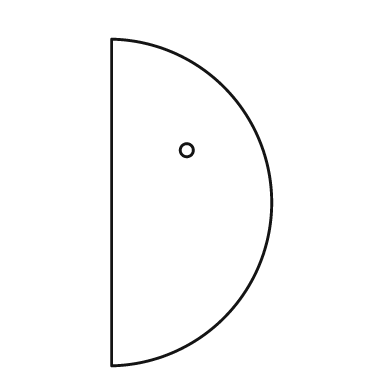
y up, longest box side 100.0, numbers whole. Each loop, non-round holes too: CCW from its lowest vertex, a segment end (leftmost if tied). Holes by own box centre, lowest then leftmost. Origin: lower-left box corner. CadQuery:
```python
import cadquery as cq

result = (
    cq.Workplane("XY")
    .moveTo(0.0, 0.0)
    .threePointArc((49.0, 50.0), (0.0, 100.0))
    .close()
    .moveTo(23.0, 66.0)
    .circle(2.0)
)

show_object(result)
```